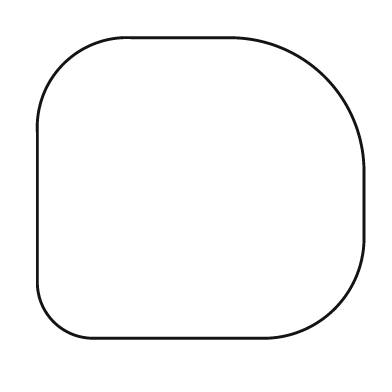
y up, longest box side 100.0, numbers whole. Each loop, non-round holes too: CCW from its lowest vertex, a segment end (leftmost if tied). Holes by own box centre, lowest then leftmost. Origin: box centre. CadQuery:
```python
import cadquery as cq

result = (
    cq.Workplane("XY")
    .moveTo(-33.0, -46.0)
    .lineTo(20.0, -46.0)
    .threePointArc((41.0, -37.0), (50.0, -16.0))
    .lineTo(50.0, 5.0)
    .threePointArc((38.0, 34.0), (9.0, 46.0))
    .lineTo(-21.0, 46.0)
    .threePointArc((-42.0, 38.0), (-50.0, 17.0))
    .lineTo(-50.0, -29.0)
    .threePointArc((-45.0, -41.0), (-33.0, -46.0))
    .close()
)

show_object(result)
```